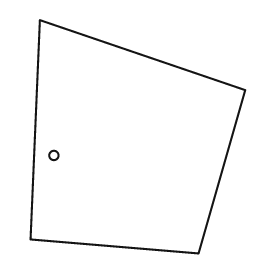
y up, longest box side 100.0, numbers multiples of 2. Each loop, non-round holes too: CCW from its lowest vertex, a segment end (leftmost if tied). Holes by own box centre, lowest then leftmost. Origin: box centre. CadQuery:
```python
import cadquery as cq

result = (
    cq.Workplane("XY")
    .moveTo(26.0, -50.0)
    .lineTo(46.0, 20.0)
    .lineTo(-42.0, 50.0)
    .lineTo(-46.0, -44.0)
    .close()
    .moveTo(-36.0, -8.0)
    .circle(2.0)
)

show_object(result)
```